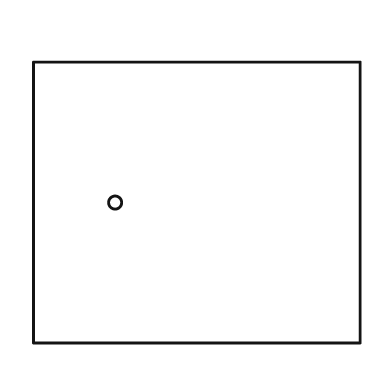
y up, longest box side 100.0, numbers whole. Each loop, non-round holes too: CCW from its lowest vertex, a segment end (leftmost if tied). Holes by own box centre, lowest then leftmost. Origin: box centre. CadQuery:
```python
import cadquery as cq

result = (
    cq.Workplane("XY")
    .moveTo(-50.0, -43.0)
    .lineTo(50.0, -43.0)
    .lineTo(50.0, 43.0)
    .lineTo(-50.0, 43.0)
    .close()
    .moveTo(-25.0, 0.0)
    .circle(2.0)
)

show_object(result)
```